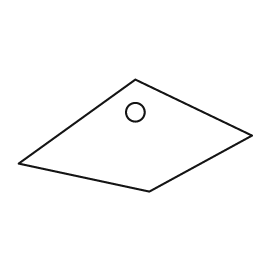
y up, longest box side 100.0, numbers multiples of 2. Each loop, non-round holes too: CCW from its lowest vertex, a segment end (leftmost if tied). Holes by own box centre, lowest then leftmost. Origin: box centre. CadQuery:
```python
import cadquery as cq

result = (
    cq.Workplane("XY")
    .moveTo(6.0, -24.0)
    .lineTo(50.0, 0.0)
    .lineTo(0.0, 24.0)
    .lineTo(-50.0, -12.0)
    .close()
    .moveTo(0.0, 10.0)
    .circle(4.0)
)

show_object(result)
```